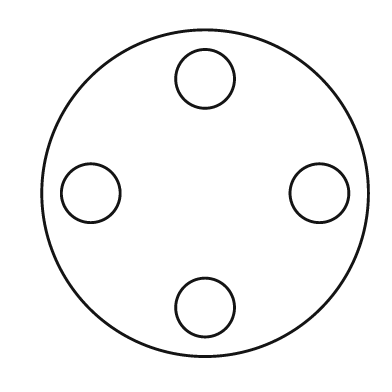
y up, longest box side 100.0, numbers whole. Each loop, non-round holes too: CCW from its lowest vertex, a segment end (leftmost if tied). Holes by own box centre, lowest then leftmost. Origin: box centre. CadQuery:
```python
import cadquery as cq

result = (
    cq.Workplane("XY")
    .moveTo(0.0, 0.0)
    .circle(50.0)
    .moveTo(0.0, -35.0)
    .circle(9.0)
    .moveTo(-35.0, 0.0)
    .circle(9.0)
    .moveTo(35.0, 0.0)
    .circle(9.0)
    .moveTo(0.0, 35.0)
    .circle(9.0)
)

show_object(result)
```